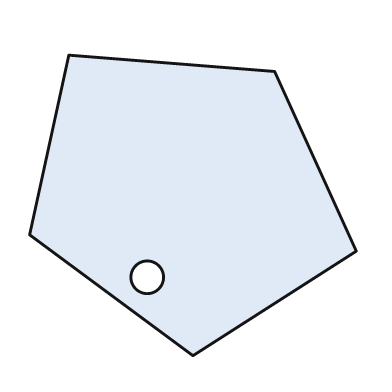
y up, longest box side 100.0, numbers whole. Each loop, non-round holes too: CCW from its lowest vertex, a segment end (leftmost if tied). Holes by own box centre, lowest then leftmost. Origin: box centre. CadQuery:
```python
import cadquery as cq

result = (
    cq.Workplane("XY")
    .moveTo(0.0, -46.0)
    .lineTo(50.0, -14.0)
    .lineTo(25.0, 41.0)
    .lineTo(-38.0, 46.0)
    .lineTo(-50.0, -9.0)
    .close()
    .moveTo(-14.0, -22.0)
    .circle(5.0)
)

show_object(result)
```